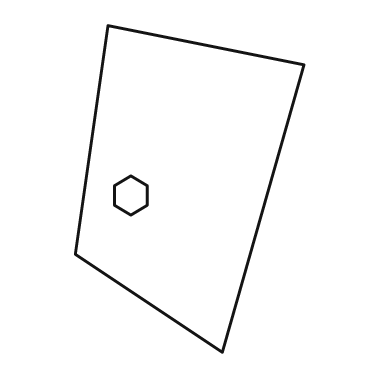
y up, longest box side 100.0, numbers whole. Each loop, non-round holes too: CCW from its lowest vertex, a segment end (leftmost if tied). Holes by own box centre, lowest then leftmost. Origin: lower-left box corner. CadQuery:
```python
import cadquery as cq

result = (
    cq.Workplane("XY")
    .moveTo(45.0, 0.0)
    .lineTo(70.0, 88.0)
    .lineTo(10.0, 100.0)
    .lineTo(0.0, 30.0)
    .close()
    .moveTo(17.0, 42.0)
    .lineTo(22.0, 45.0)
    .lineTo(22.0, 51.0)
    .lineTo(17.0, 54.0)
    .lineTo(12.0, 51.0)
    .lineTo(12.0, 45.0)
    .close()
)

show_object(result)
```